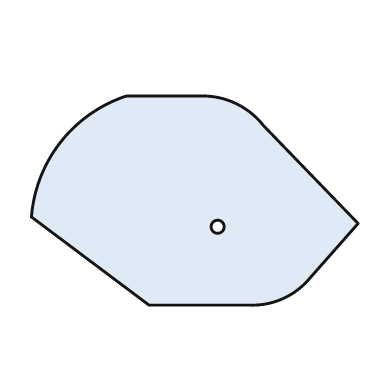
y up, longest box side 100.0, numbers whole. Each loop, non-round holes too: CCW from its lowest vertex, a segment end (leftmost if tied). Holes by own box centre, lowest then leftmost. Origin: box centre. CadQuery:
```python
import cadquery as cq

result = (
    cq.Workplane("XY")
    .moveTo(-14.0, -32.0)
    .lineTo(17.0, -32.0)
    .threePointArc((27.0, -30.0), (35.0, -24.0))
    .lineTo(50.0, -7.0)
    .lineTo(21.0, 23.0)
    .threePointArc((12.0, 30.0), (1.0, 32.0))
    .lineTo(-21.0, 32.0)
    .threePointArc((-41.0, 18.0), (-50.0, -5.0))
    .close()
    .moveTo(7.0, -8.0)
    .circle(2.0)
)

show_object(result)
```